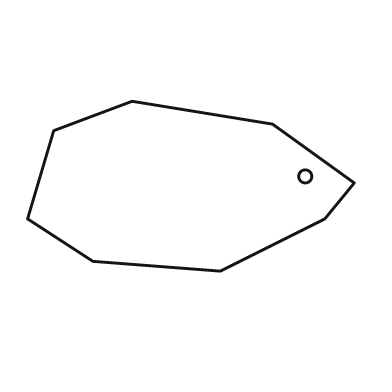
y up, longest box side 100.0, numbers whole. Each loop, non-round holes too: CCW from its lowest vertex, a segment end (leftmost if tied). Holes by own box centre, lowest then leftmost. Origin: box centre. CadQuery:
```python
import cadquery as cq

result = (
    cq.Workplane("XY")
    .moveTo(9.0, -26.0)
    .lineTo(41.0, -10.0)
    .lineTo(50.0, 1.0)
    .lineTo(25.0, 19.0)
    .lineTo(-18.0, 26.0)
    .lineTo(-42.0, 17.0)
    .lineTo(-50.0, -10.0)
    .lineTo(-30.0, -23.0)
    .close()
    .moveTo(35.0, 3.0)
    .circle(2.0)
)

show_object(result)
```